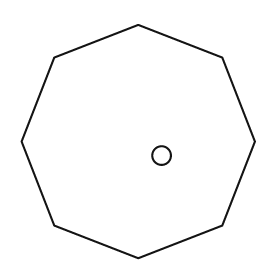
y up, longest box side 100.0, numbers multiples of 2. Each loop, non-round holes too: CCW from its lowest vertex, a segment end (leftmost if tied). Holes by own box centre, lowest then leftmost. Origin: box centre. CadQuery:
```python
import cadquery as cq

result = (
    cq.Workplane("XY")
    .moveTo(0.0, -50.0)
    .lineTo(36.0, -36.0)
    .lineTo(50.0, 0.0)
    .lineTo(36.0, 36.0)
    .lineTo(0.0, 50.0)
    .lineTo(-36.0, 36.0)
    .lineTo(-50.0, 0.0)
    .lineTo(-36.0, -36.0)
    .close()
    .moveTo(10.0, -6.0)
    .circle(4.0)
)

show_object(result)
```